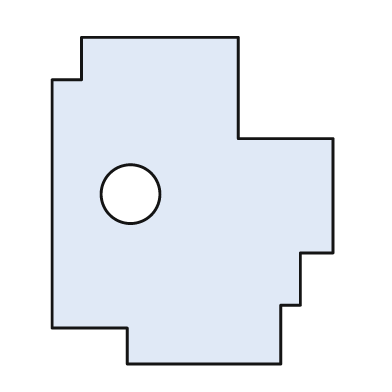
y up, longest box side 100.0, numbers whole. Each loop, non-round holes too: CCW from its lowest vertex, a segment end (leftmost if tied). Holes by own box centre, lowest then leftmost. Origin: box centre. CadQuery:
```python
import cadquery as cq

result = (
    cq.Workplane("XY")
    .moveTo(-20.0, -50.0)
    .lineTo(27.0, -50.0)
    .lineTo(27.0, -32.0)
    .lineTo(33.0, -32.0)
    .lineTo(33.0, -16.0)
    .lineTo(43.0, -16.0)
    .lineTo(43.0, 19.0)
    .lineTo(14.0, 19.0)
    .lineTo(14.0, 50.0)
    .lineTo(-34.0, 50.0)
    .lineTo(-34.0, 37.0)
    .lineTo(-43.0, 37.0)
    .lineTo(-43.0, -39.0)
    .lineTo(-20.0, -39.0)
    .close()
    .moveTo(-19.0, 2.0)
    .circle(9.0)
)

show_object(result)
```